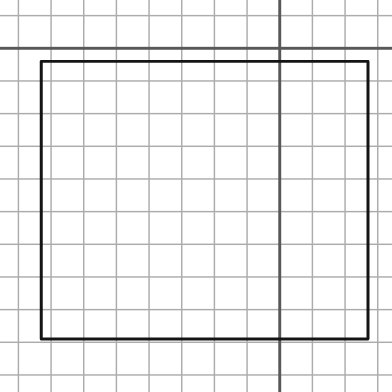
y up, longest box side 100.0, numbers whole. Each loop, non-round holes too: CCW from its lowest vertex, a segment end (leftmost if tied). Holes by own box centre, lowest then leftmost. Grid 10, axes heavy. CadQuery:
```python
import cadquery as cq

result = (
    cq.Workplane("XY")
    .moveTo(-73.0, -89.0)
    .lineTo(27.0, -89.0)
    .lineTo(27.0, -4.0)
    .lineTo(-73.0, -4.0)
    .close()
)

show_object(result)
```